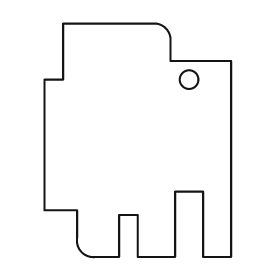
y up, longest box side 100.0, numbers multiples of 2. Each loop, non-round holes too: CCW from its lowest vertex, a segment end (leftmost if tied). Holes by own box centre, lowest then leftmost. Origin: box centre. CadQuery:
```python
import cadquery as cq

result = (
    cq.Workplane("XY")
    .moveTo(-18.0, -50.0)
    .lineTo(-8.0, -50.0)
    .lineTo(-8.0, -32.0)
    .lineTo(0.0, -32.0)
    .lineTo(0.0, -50.0)
    .lineTo(16.0, -50.0)
    .lineTo(16.0, -22.0)
    .lineTo(28.0, -22.0)
    .lineTo(28.0, -50.0)
    .lineTo(40.0, -50.0)
    .lineTo(40.0, 34.0)
    .lineTo(14.0, 34.0)
    .lineTo(14.0, 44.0)
    .threePointArc((12.0, 48.0), (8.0, 50.0))
    .lineTo(-32.0, 50.0)
    .lineTo(-32.0, 26.0)
    .lineTo(-40.0, 26.0)
    .lineTo(-40.0, -30.0)
    .lineTo(-26.0, -30.0)
    .lineTo(-26.0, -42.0)
    .threePointArc((-24.0, -48.0), (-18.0, -50.0))
    .close()
    .moveTo(22.0, 26.0)
    .circle(4.0)
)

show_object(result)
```